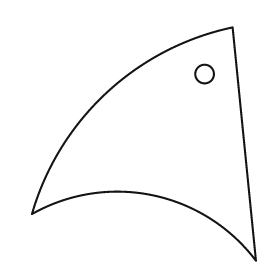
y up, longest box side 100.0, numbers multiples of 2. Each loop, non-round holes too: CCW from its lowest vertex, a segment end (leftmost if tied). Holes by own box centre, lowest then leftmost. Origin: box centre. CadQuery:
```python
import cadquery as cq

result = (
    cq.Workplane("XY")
    .moveTo(48.0, -50.0)
    .lineTo(38.0, 50.0)
    .threePointArc((-16.0, 22.0), (-48.0, -30.0))
    .threePointArc((4.0, -22.0), (48.0, -50.0))
    .close()
    .moveTo(26.0, 30.0)
    .circle(4.0)
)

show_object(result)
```